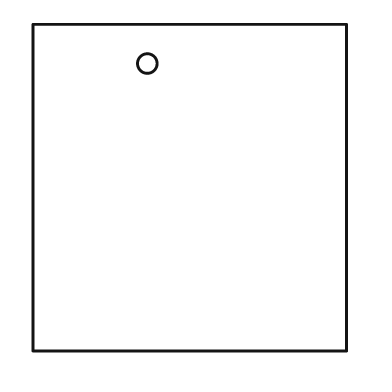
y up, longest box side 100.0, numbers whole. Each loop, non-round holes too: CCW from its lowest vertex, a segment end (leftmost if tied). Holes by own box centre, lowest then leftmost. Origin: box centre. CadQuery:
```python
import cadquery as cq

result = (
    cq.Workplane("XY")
    .moveTo(-48.0, -50.0)
    .lineTo(48.0, -50.0)
    .lineTo(48.0, 50.0)
    .lineTo(-48.0, 50.0)
    .close()
    .moveTo(-13.0, 38.0)
    .circle(3.0)
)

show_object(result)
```